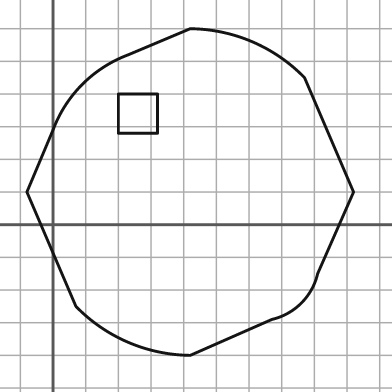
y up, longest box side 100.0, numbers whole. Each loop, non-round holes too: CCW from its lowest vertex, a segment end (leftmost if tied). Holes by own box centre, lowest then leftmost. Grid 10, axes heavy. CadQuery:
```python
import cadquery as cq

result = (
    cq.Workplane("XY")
    .moveTo(42.0, -40.0)
    .lineTo(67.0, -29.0)
    .threePointArc((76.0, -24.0), (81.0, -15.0))
    .lineTo(92.0, 10.0)
    .lineTo(77.0, 45.0)
    .threePointArc((61.0, 56.0), (42.0, 60.0))
    .lineTo(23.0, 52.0)
    .threePointArc((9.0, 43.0), (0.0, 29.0))
    .lineTo(-8.0, 10.0)
    .lineTo(7.0, -25.0)
    .threePointArc((23.0, -36.0), (42.0, -40.0))
    .close()
    .moveTo(20.0, 28.0)
    .lineTo(32.0, 28.0)
    .lineTo(32.0, 40.0)
    .lineTo(20.0, 40.0)
    .close()
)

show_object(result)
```